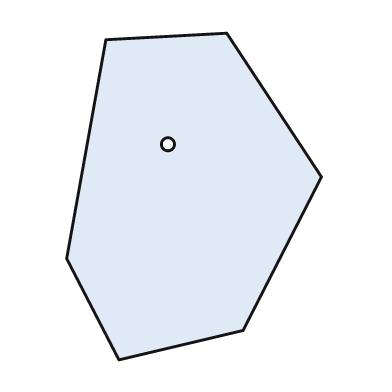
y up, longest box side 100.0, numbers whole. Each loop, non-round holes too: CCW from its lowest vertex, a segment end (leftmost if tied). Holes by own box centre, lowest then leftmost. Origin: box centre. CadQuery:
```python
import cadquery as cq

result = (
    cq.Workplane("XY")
    .moveTo(-23.0, -50.0)
    .lineTo(15.0, -41.0)
    .lineTo(39.0, 6.0)
    .lineTo(10.0, 50.0)
    .lineTo(-27.0, 48.0)
    .lineTo(-39.0, -19.0)
    .close()
    .moveTo(-8.0, 16.0)
    .circle(2.0)
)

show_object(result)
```